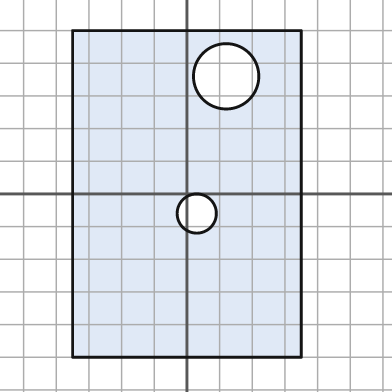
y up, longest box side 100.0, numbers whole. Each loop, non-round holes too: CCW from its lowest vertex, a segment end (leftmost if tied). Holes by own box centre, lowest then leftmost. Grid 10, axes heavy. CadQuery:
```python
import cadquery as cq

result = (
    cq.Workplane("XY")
    .moveTo(-35.0, -50.0)
    .lineTo(35.0, -50.0)
    .lineTo(35.0, 50.0)
    .lineTo(-35.0, 50.0)
    .close()
    .moveTo(3.0, -6.0)
    .circle(6.0)
    .moveTo(12.0, 36.0)
    .circle(10.0)
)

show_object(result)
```